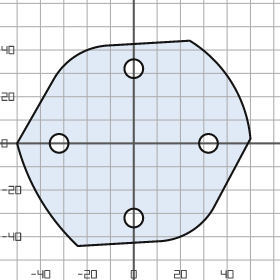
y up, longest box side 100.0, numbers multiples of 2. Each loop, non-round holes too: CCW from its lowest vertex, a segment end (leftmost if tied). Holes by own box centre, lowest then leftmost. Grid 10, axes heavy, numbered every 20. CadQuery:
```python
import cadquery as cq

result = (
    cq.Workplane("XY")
    .moveTo(-24.0, -44.0)
    .lineTo(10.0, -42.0)
    .threePointArc((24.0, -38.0), (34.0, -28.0))
    .lineTo(50.0, 2.0)
    .threePointArc((42.0, 26.0), (24.0, 44.0))
    .lineTo(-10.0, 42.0)
    .threePointArc((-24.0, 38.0), (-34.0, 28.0))
    .lineTo(-50.0, 0.0)
    .threePointArc((-40.0, -24.0), (-24.0, -44.0))
    .close()
    .moveTo(0.0, -32.0)
    .circle(4.0)
    .moveTo(-32.0, 0.0)
    .circle(4.0)
    .moveTo(32.0, 0.0)
    .circle(4.0)
    .moveTo(0.0, 32.0)
    .circle(4.0)
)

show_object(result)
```